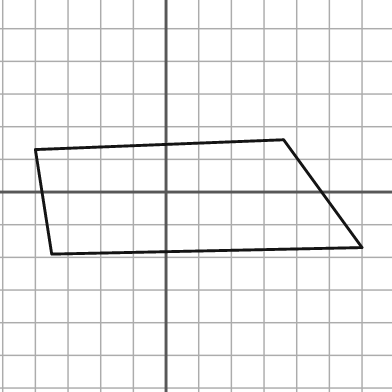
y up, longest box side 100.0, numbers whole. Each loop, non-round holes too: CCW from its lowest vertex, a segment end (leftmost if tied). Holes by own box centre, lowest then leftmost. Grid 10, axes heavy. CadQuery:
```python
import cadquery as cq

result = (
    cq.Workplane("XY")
    .moveTo(-35.0, -19.0)
    .lineTo(60.0, -17.0)
    .lineTo(36.0, 16.0)
    .lineTo(-40.0, 13.0)
    .close()
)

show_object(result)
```